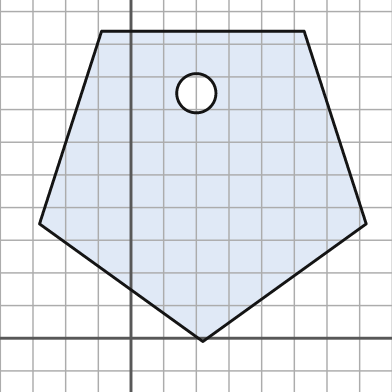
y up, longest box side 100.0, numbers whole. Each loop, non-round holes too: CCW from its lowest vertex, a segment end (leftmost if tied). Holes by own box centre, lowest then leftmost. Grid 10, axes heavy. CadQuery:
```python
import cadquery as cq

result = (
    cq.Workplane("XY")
    .moveTo(22.0, -1.0)
    .lineTo(72.0, 35.0)
    .lineTo(53.0, 94.0)
    .lineTo(-9.0, 94.0)
    .lineTo(-28.0, 35.0)
    .close()
    .moveTo(20.0, 75.0)
    .circle(6.0)
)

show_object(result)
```